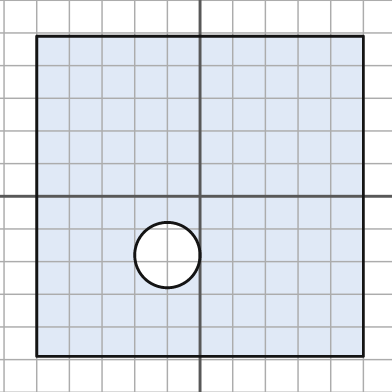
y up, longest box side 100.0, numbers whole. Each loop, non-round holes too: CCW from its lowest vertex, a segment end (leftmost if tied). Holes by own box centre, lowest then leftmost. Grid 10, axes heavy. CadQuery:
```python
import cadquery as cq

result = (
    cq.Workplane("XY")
    .moveTo(-50.0, -49.0)
    .lineTo(50.0, -49.0)
    .lineTo(50.0, 49.0)
    .lineTo(-50.0, 49.0)
    .close()
    .moveTo(-10.0, -18.0)
    .circle(10.0)
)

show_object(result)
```